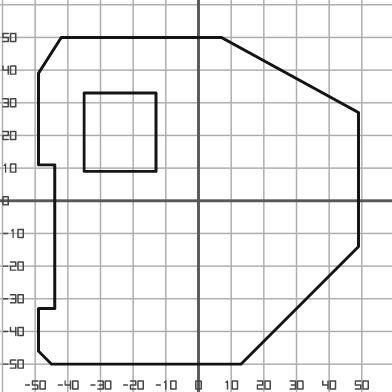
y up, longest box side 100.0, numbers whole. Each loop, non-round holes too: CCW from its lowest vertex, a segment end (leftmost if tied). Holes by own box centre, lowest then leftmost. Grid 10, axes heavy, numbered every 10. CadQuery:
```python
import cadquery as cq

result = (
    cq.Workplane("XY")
    .moveTo(-45.0, -50.0)
    .lineTo(13.0, -50.0)
    .lineTo(49.0, -14.0)
    .lineTo(49.0, 27.0)
    .lineTo(7.0, 50.0)
    .lineTo(-42.0, 50.0)
    .lineTo(-49.0, 39.0)
    .lineTo(-49.0, 11.0)
    .lineTo(-44.0, 11.0)
    .lineTo(-44.0, -33.0)
    .lineTo(-49.0, -33.0)
    .lineTo(-49.0, -46.0)
    .close()
    .moveTo(-35.0, 9.0)
    .lineTo(-13.0, 9.0)
    .lineTo(-13.0, 33.0)
    .lineTo(-35.0, 33.0)
    .close()
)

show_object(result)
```